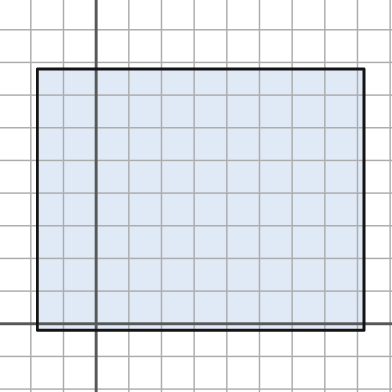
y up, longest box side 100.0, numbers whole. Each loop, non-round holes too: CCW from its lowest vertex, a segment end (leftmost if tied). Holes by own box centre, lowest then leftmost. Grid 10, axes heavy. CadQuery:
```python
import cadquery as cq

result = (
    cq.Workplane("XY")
    .moveTo(-18.0, -2.0)
    .lineTo(82.0, -2.0)
    .lineTo(82.0, 78.0)
    .lineTo(-18.0, 78.0)
    .close()
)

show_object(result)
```